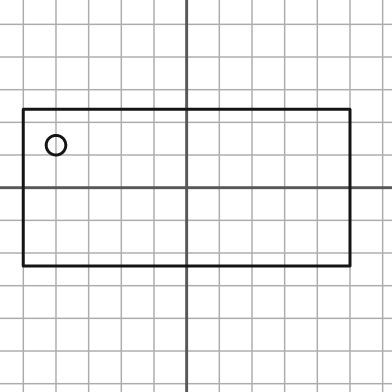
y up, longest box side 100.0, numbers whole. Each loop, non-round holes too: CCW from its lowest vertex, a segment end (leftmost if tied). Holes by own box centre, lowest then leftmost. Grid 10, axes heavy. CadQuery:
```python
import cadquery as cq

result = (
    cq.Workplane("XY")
    .moveTo(-50.0, -24.0)
    .lineTo(50.0, -24.0)
    .lineTo(50.0, 24.0)
    .lineTo(-50.0, 24.0)
    .close()
    .moveTo(-40.0, 13.0)
    .circle(3.0)
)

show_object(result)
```